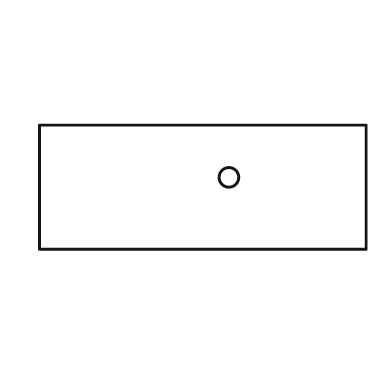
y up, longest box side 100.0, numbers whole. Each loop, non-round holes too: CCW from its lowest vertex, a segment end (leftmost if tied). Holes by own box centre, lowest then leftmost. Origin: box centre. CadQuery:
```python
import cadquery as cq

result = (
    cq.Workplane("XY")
    .moveTo(-50.0, -19.0)
    .lineTo(50.0, -19.0)
    .lineTo(50.0, 19.0)
    .lineTo(-50.0, 19.0)
    .close()
    .moveTo(8.0, 3.0)
    .circle(3.0)
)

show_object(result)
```